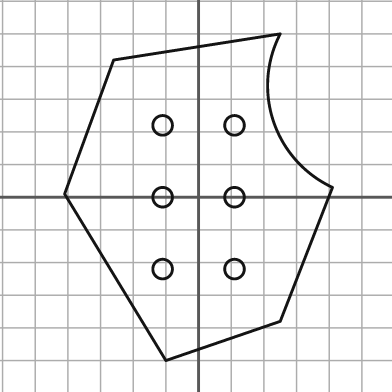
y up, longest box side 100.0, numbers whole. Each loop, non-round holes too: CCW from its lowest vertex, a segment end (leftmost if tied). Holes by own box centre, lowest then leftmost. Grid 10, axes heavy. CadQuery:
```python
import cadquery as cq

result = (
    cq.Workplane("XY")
    .moveTo(-10.0, -50.0)
    .lineTo(25.0, -38.0)
    .lineTo(41.0, 3.0)
    .threePointArc((23.0, 23.0), (25.0, 50.0))
    .lineTo(-26.0, 42.0)
    .lineTo(-41.0, 1.0)
    .close()
    .moveTo(-11.0, -22.0)
    .circle(3.0)
    .moveTo(11.0, -22.0)
    .circle(3.0)
    .moveTo(-11.0, 0.0)
    .circle(3.0)
    .moveTo(11.0, 0.0)
    .circle(3.0)
    .moveTo(-11.0, 22.0)
    .circle(3.0)
    .moveTo(11.0, 22.0)
    .circle(3.0)
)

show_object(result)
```